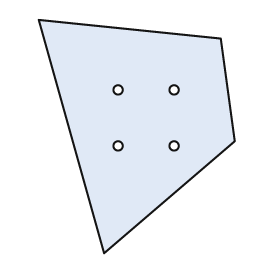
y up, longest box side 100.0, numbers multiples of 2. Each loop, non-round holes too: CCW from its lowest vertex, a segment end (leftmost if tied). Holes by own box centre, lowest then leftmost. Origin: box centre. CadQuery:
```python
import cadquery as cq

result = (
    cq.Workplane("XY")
    .moveTo(-14.0, -50.0)
    .lineTo(42.0, -2.0)
    .lineTo(36.0, 42.0)
    .lineTo(-42.0, 50.0)
    .close()
    .moveTo(-8.0, -4.0)
    .circle(2.0)
    .moveTo(16.0, -4.0)
    .circle(2.0)
    .moveTo(-8.0, 20.0)
    .circle(2.0)
    .moveTo(16.0, 20.0)
    .circle(2.0)
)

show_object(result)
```